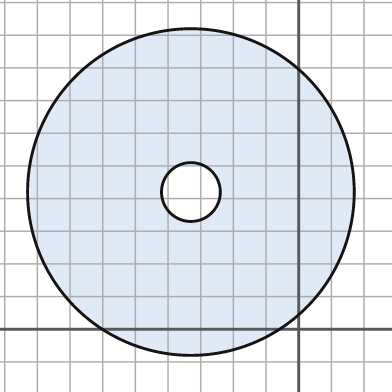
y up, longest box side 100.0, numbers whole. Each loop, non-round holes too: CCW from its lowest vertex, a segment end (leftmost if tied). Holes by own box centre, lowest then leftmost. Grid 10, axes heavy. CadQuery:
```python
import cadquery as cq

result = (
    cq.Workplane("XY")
    .moveTo(-33.0, 42.0)
    .circle(50.0)
    .moveTo(-33.0, 42.0)
    .circle(9.0)
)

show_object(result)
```